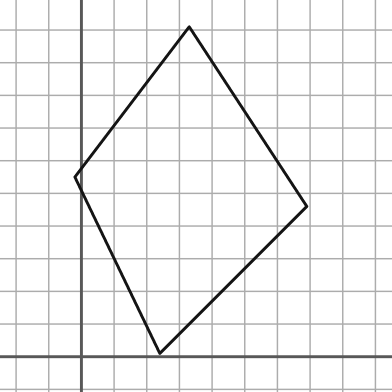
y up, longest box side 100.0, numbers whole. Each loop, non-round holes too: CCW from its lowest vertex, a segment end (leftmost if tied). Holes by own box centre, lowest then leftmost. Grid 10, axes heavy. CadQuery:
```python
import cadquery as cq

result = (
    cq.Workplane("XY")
    .moveTo(24.0, 1.0)
    .lineTo(69.0, 46.0)
    .lineTo(33.0, 101.0)
    .lineTo(-2.0, 55.0)
    .close()
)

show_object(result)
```